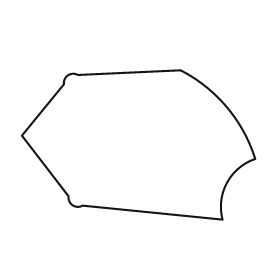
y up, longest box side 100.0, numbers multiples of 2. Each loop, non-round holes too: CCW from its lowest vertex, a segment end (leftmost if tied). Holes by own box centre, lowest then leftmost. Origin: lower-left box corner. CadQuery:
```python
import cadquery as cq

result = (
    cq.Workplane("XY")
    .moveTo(86.0, 0.0)
    .threePointArc((88.0, 16.0), (100.0, 26.0))
    .threePointArc((88.0, 48.0), (68.0, 64.0))
    .lineTo(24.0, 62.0)
    .threePointArc((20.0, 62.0), (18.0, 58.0))
    .lineTo(0.0, 36.0)
    .lineTo(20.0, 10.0)
    .threePointArc((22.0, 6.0), (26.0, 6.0))
    .close()
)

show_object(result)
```